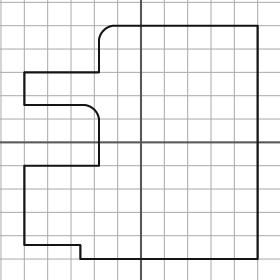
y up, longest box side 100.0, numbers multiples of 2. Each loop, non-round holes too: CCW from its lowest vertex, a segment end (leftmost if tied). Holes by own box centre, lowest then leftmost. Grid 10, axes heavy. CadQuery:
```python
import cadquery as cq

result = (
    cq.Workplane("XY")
    .moveTo(-26.0, -50.0)
    .lineTo(50.0, -50.0)
    .lineTo(50.0, 50.0)
    .lineTo(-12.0, 50.0)
    .threePointArc((-16.0, 48.0), (-18.0, 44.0))
    .lineTo(-18.0, 30.0)
    .lineTo(-50.0, 30.0)
    .lineTo(-50.0, 16.0)
    .lineTo(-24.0, 16.0)
    .threePointArc((-20.0, 14.0), (-18.0, 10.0))
    .lineTo(-18.0, -10.0)
    .lineTo(-50.0, -10.0)
    .lineTo(-50.0, -44.0)
    .lineTo(-26.0, -44.0)
    .close()
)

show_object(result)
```